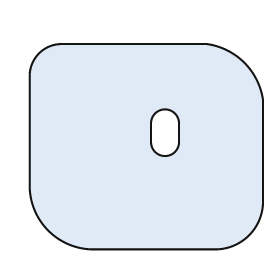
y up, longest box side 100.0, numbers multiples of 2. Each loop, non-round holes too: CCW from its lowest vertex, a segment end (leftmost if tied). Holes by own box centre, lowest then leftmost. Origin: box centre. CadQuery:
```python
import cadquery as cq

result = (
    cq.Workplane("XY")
    .moveTo(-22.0, -44.0)
    .lineTo(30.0, -44.0)
    .threePointArc((44.0, -38.0), (50.0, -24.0))
    .lineTo(50.0, 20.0)
    .threePointArc((42.0, 36.0), (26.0, 44.0))
    .lineTo(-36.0, 44.0)
    .threePointArc((-46.0, 40.0), (-50.0, 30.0))
    .lineTo(-50.0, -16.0)
    .threePointArc((-42.0, -36.0), (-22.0, -44.0))
    .close()
    .moveTo(2.0, 2.0)
    .threePointArc((8.0, -4.0), (14.0, 2.0))
    .lineTo(14.0, 10.0)
    .threePointArc((8.0, 16.0), (2.0, 10.0))
    .close()
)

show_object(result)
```